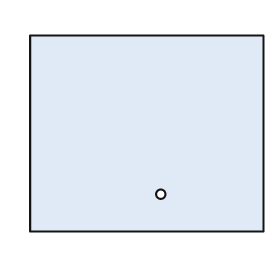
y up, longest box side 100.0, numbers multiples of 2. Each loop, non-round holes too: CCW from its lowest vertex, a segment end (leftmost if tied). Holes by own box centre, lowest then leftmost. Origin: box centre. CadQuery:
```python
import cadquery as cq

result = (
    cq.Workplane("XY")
    .moveTo(-50.0, -42.0)
    .lineTo(50.0, -42.0)
    .lineTo(50.0, 42.0)
    .lineTo(-50.0, 42.0)
    .close()
    .moveTo(6.0, -26.0)
    .circle(2.0)
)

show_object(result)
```